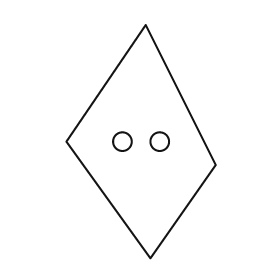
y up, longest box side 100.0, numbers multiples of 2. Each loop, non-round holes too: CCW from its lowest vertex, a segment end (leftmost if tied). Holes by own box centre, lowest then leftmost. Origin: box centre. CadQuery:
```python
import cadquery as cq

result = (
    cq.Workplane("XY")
    .moveTo(4.0, -50.0)
    .lineTo(32.0, -10.0)
    .lineTo(2.0, 50.0)
    .lineTo(-32.0, 0.0)
    .close()
    .moveTo(-8.0, 0.0)
    .circle(4.0)
    .moveTo(8.0, 0.0)
    .circle(4.0)
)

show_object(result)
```